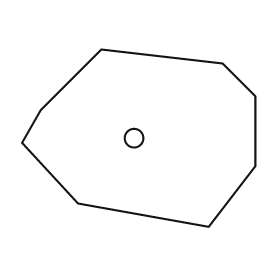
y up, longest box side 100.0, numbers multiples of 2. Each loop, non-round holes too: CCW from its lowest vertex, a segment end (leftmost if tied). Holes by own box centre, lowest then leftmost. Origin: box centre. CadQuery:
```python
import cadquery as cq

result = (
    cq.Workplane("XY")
    .moveTo(30.0, -38.0)
    .lineTo(50.0, -12.0)
    .lineTo(50.0, 18.0)
    .lineTo(36.0, 32.0)
    .lineTo(-16.0, 38.0)
    .lineTo(-42.0, 12.0)
    .lineTo(-50.0, -2.0)
    .lineTo(-26.0, -28.0)
    .close()
    .moveTo(-2.0, 0.0)
    .circle(4.0)
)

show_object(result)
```